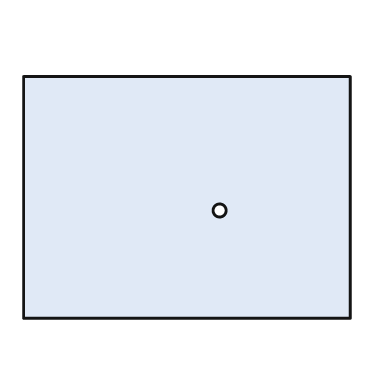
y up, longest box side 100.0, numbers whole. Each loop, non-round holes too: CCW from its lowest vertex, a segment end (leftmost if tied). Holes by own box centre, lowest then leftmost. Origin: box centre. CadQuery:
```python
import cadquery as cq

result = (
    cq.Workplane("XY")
    .moveTo(-50.0, -37.0)
    .lineTo(50.0, -37.0)
    .lineTo(50.0, 37.0)
    .lineTo(-50.0, 37.0)
    .close()
    .moveTo(10.0, -4.0)
    .circle(2.0)
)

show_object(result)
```